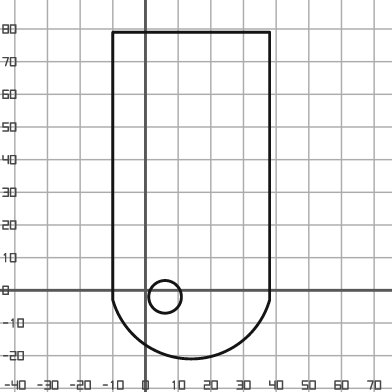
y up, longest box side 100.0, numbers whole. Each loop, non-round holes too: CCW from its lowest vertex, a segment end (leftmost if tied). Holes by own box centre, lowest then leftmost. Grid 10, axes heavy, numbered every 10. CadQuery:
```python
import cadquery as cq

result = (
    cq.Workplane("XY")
    .moveTo(-10.0, -3.0)
    .threePointArc((14.0, -21.0), (38.0, -3.0))
    .lineTo(38.0, 79.0)
    .lineTo(-10.0, 79.0)
    .close()
    .moveTo(6.0, -2.0)
    .circle(5.0)
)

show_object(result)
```